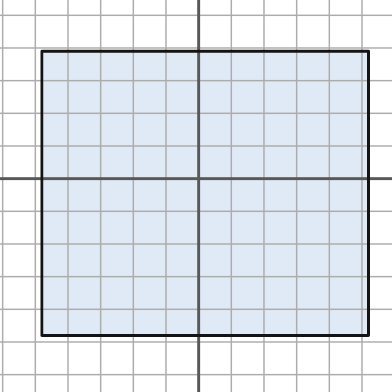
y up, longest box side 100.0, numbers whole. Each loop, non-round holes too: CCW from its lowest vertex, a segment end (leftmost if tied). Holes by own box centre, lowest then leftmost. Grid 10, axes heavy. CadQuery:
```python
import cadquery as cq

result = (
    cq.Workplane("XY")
    .moveTo(-48.0, -48.0)
    .lineTo(52.0, -48.0)
    .lineTo(52.0, 39.0)
    .lineTo(-48.0, 39.0)
    .close()
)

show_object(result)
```